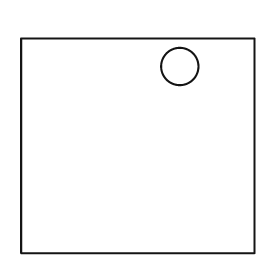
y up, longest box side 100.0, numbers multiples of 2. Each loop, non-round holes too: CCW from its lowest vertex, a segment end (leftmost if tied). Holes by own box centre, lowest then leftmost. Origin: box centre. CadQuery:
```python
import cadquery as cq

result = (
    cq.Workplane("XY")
    .moveTo(-50.0, -46.0)
    .lineTo(50.0, -46.0)
    .lineTo(50.0, 46.0)
    .lineTo(-50.0, 46.0)
    .close()
    .moveTo(18.0, 34.0)
    .circle(8.0)
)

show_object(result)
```